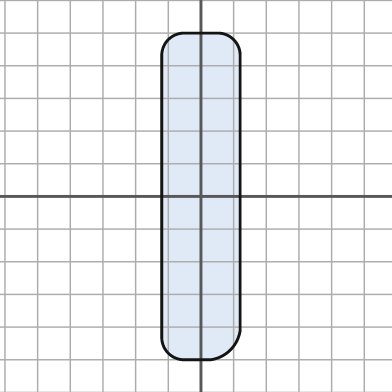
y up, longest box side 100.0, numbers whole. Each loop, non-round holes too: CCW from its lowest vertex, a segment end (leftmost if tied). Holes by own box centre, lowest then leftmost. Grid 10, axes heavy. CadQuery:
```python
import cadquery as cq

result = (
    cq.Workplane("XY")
    .moveTo(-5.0, -50.0)
    .lineTo(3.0, -50.0)
    .threePointArc((9.0, -47.0), (12.0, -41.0))
    .lineTo(12.0, 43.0)
    .threePointArc((10.0, 48.0), (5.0, 50.0))
    .lineTo(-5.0, 50.0)
    .threePointArc((-10.0, 48.0), (-12.0, 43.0))
    .lineTo(-12.0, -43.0)
    .threePointArc((-10.0, -48.0), (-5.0, -50.0))
    .close()
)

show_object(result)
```